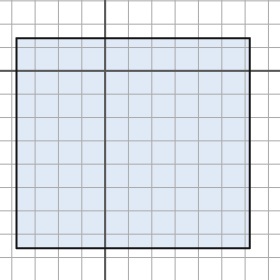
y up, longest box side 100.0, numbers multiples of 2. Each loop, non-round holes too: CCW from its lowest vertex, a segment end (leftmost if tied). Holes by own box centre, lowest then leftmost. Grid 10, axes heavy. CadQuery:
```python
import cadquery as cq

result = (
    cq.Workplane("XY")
    .moveTo(-38.0, -76.0)
    .lineTo(62.0, -76.0)
    .lineTo(62.0, 14.0)
    .lineTo(-38.0, 14.0)
    .close()
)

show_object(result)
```